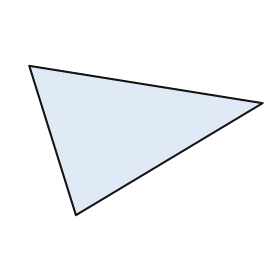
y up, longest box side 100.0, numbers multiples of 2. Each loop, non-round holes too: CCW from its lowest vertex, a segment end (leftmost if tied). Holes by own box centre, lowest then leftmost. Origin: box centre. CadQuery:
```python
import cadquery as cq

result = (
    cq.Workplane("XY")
    .moveTo(-30.0, -32.0)
    .lineTo(50.0, 16.0)
    .lineTo(-50.0, 32.0)
    .close()
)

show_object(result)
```